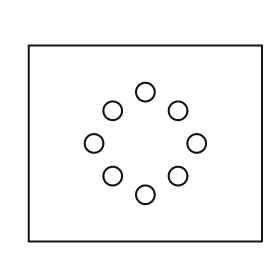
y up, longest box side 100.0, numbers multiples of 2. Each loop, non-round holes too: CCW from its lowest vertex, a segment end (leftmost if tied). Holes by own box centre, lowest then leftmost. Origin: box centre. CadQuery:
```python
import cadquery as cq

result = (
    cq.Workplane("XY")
    .moveTo(-50.0, -42.0)
    .lineTo(50.0, -42.0)
    .lineTo(50.0, 42.0)
    .lineTo(-50.0, 42.0)
    .close()
    .moveTo(0.0, -22.0)
    .circle(4.0)
    .moveTo(-14.0, -14.0)
    .circle(4.0)
    .moveTo(14.0, -14.0)
    .circle(4.0)
    .moveTo(-22.0, 0.0)
    .circle(4.0)
    .moveTo(22.0, 0.0)
    .circle(4.0)
    .moveTo(-14.0, 14.0)
    .circle(4.0)
    .moveTo(14.0, 14.0)
    .circle(4.0)
    .moveTo(0.0, 22.0)
    .circle(4.0)
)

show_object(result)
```